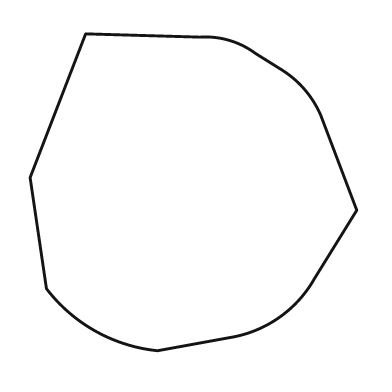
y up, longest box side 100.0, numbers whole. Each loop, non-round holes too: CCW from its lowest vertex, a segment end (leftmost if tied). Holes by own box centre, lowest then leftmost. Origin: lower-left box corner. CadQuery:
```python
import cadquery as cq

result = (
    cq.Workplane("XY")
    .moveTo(39.0, 0.0)
    .lineTo(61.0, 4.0)
    .threePointArc((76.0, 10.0), (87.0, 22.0))
    .lineTo(100.0, 43.0)
    .lineTo(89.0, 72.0)
    .threePointArc((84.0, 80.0), (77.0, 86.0))
    .lineTo(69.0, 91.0)
    .threePointArc((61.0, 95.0), (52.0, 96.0))
    .lineTo(17.0, 97.0)
    .lineTo(0.0, 53.0)
    .lineTo(5.0, 19.0)
    .threePointArc((20.0, 6.0), (39.0, 0.0))
    .close()
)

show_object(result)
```